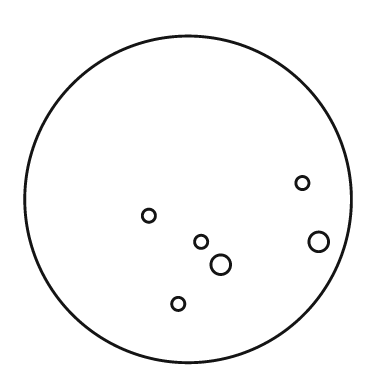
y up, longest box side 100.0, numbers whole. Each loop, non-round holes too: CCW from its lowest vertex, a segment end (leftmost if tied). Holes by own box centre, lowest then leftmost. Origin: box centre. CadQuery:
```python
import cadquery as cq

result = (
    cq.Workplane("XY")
    .moveTo(0.0, 0.0)
    .circle(50.0)
    .moveTo(-3.0, -32.0)
    .circle(2.0)
    .moveTo(10.0, -20.0)
    .circle(3.0)
    .moveTo(4.0, -13.0)
    .circle(2.0)
    .moveTo(40.0, -13.0)
    .circle(3.0)
    .moveTo(-12.0, -5.0)
    .circle(2.0)
    .moveTo(35.0, 5.0)
    .circle(2.0)
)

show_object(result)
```